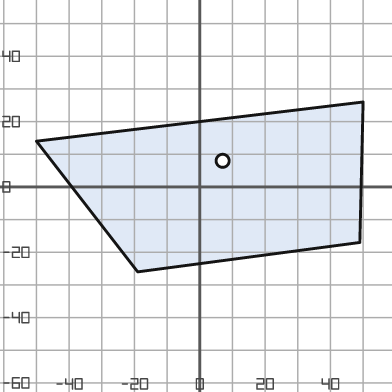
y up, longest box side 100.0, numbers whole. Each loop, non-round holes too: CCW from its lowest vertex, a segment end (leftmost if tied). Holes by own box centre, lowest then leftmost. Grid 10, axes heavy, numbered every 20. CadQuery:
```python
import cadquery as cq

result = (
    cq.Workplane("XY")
    .moveTo(-19.0, -26.0)
    .lineTo(49.0, -17.0)
    .lineTo(50.0, 26.0)
    .lineTo(-50.0, 14.0)
    .close()
    .moveTo(7.0, 8.0)
    .circle(2.0)
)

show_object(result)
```